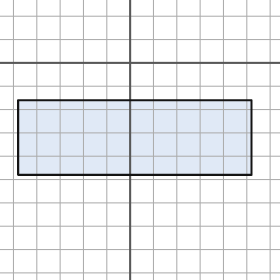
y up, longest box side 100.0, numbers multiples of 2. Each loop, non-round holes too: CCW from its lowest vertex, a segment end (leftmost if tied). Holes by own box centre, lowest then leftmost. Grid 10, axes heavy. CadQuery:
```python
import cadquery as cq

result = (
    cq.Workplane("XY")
    .moveTo(-48.0, -48.0)
    .lineTo(52.0, -48.0)
    .lineTo(52.0, -16.0)
    .lineTo(-48.0, -16.0)
    .close()
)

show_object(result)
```